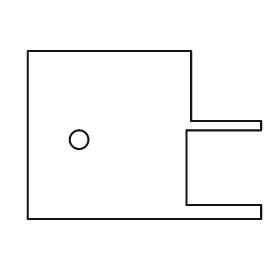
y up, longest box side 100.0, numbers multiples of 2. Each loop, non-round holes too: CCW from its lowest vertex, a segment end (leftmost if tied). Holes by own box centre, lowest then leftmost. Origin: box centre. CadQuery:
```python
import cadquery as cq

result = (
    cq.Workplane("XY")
    .moveTo(-50.0, -36.0)
    .lineTo(50.0, -36.0)
    .lineTo(50.0, -30.0)
    .lineTo(18.0, -30.0)
    .lineTo(18.0, 2.0)
    .lineTo(50.0, 2.0)
    .lineTo(50.0, 6.0)
    .lineTo(20.0, 6.0)
    .lineTo(20.0, 36.0)
    .lineTo(-50.0, 36.0)
    .close()
    .moveTo(-28.0, -2.0)
    .circle(4.0)
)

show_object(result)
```